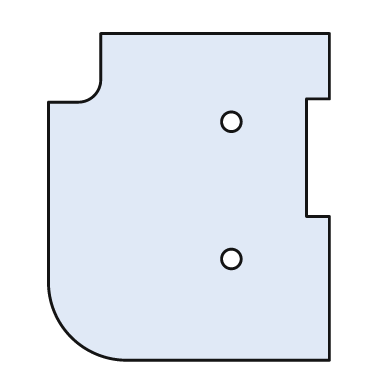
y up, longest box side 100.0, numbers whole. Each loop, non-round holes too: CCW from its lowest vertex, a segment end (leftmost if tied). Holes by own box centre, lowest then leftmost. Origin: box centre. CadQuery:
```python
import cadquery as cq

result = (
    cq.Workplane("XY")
    .moveTo(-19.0, -50.0)
    .lineTo(43.0, -50.0)
    .lineTo(43.0, -6.0)
    .lineTo(36.0, -6.0)
    .lineTo(36.0, 30.0)
    .lineTo(43.0, 30.0)
    .lineTo(43.0, 50.0)
    .lineTo(-27.0, 50.0)
    .lineTo(-27.0, 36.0)
    .threePointArc((-29.0, 31.0), (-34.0, 29.0))
    .lineTo(-43.0, 29.0)
    .lineTo(-43.0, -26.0)
    .threePointArc((-36.0, -43.0), (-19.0, -50.0))
    .close()
    .moveTo(13.0, -19.0)
    .circle(3.0)
    .moveTo(13.0, 23.0)
    .circle(3.0)
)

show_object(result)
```